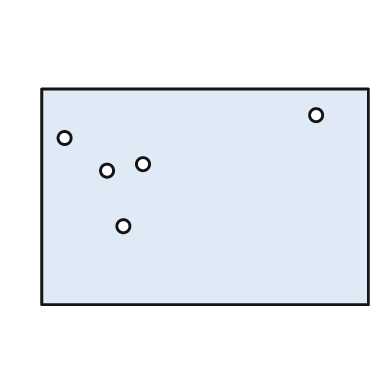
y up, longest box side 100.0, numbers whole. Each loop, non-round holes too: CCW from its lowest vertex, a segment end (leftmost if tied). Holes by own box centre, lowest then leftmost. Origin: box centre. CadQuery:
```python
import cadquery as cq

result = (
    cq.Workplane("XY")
    .moveTo(-50.0, -33.0)
    .lineTo(50.0, -33.0)
    .lineTo(50.0, 33.0)
    .lineTo(-50.0, 33.0)
    .close()
    .moveTo(-25.0, -9.0)
    .circle(2.0)
    .moveTo(-30.0, 8.0)
    .circle(2.0)
    .moveTo(-19.0, 10.0)
    .circle(2.0)
    .moveTo(-43.0, 18.0)
    .circle(2.0)
    .moveTo(34.0, 25.0)
    .circle(2.0)
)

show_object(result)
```